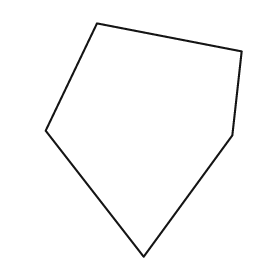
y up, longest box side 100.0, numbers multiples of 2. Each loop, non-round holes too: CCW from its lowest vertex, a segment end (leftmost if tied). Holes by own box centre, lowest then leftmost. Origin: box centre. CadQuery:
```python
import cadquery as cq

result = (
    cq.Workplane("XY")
    .moveTo(0.0, -50.0)
    .lineTo(38.0, 2.0)
    .lineTo(42.0, 38.0)
    .lineTo(-20.0, 50.0)
    .lineTo(-42.0, 4.0)
    .close()
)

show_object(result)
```